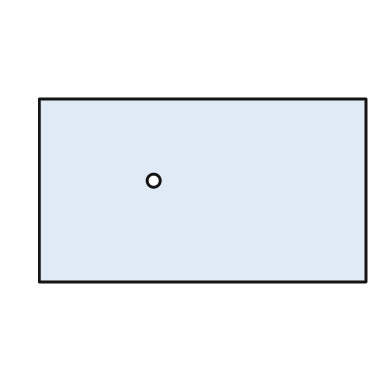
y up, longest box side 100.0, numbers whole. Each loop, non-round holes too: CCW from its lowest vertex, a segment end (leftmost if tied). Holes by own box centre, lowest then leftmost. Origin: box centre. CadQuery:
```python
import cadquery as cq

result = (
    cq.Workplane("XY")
    .moveTo(-50.0, -28.0)
    .lineTo(50.0, -28.0)
    .lineTo(50.0, 28.0)
    .lineTo(-50.0, 28.0)
    .close()
    .moveTo(-15.0, 3.0)
    .circle(2.0)
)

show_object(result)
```